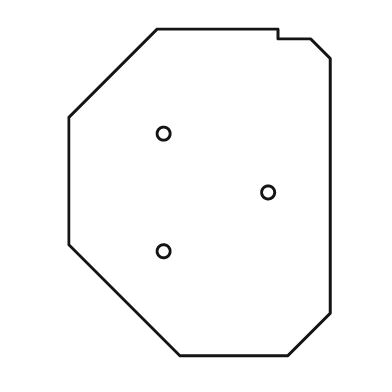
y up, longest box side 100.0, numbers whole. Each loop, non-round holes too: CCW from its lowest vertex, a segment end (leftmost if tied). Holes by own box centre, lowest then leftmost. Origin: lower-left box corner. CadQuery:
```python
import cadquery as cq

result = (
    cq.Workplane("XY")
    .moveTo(34.0, 0.0)
    .lineTo(67.0, 0.0)
    .lineTo(80.0, 13.0)
    .lineTo(80.0, 91.0)
    .lineTo(74.0, 97.0)
    .lineTo(64.0, 97.0)
    .lineTo(64.0, 100.0)
    .lineTo(27.0, 100.0)
    .lineTo(0.0, 73.0)
    .lineTo(0.0, 34.0)
    .close()
    .moveTo(29.0, 32.0)
    .circle(2.0)
    .moveTo(61.0, 50.0)
    .circle(2.0)
    .moveTo(29.0, 68.0)
    .circle(2.0)
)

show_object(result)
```